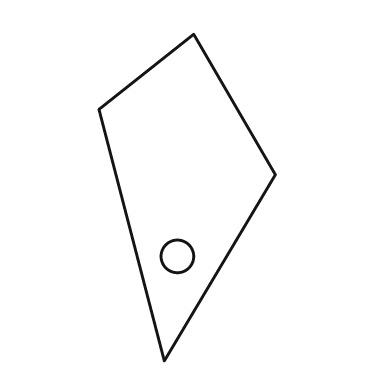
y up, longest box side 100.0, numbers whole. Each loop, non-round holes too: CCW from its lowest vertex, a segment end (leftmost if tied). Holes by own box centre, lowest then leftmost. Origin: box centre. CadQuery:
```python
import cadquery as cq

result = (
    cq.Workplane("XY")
    .moveTo(-7.0, -50.0)
    .lineTo(27.0, 7.0)
    .lineTo(2.0, 50.0)
    .lineTo(-27.0, 27.0)
    .close()
    .moveTo(-3.0, -18.0)
    .circle(5.0)
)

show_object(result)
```